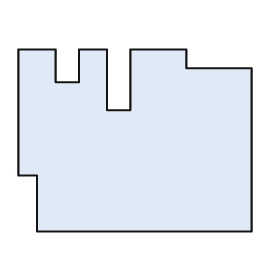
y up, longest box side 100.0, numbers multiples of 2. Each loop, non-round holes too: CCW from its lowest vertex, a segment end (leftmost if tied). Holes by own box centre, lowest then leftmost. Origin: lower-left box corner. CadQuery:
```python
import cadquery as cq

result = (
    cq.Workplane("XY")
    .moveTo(8.0, 0.0)
    .lineTo(100.0, 0.0)
    .lineTo(100.0, 70.0)
    .lineTo(72.0, 70.0)
    .lineTo(72.0, 78.0)
    .lineTo(48.0, 78.0)
    .lineTo(48.0, 52.0)
    .lineTo(38.0, 52.0)
    .lineTo(38.0, 78.0)
    .lineTo(26.0, 78.0)
    .lineTo(26.0, 64.0)
    .lineTo(16.0, 64.0)
    .lineTo(16.0, 78.0)
    .lineTo(0.0, 78.0)
    .lineTo(0.0, 24.0)
    .lineTo(8.0, 24.0)
    .close()
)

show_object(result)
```